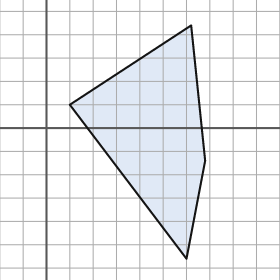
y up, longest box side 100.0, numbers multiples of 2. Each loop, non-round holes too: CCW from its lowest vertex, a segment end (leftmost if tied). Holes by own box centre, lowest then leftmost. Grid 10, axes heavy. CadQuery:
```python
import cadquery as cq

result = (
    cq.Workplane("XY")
    .moveTo(60.0, -56.0)
    .lineTo(68.0, -14.0)
    .lineTo(62.0, 44.0)
    .lineTo(10.0, 10.0)
    .close()
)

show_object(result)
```